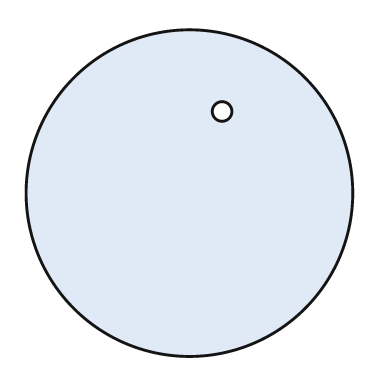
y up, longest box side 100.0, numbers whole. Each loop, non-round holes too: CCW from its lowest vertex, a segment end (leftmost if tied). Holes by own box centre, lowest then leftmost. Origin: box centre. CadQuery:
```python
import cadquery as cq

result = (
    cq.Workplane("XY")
    .moveTo(0.0, 0.0)
    .circle(50.0)
    .moveTo(10.0, 25.0)
    .circle(3.0)
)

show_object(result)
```